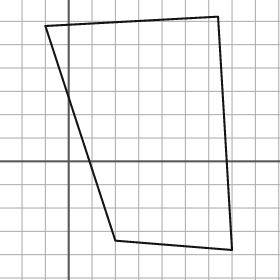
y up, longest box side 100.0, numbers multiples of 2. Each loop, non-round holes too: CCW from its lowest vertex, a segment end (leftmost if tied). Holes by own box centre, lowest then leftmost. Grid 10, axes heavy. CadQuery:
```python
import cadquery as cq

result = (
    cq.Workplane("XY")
    .moveTo(70.0, -38.0)
    .lineTo(64.0, 62.0)
    .lineTo(-10.0, 58.0)
    .lineTo(20.0, -34.0)
    .close()
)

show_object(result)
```